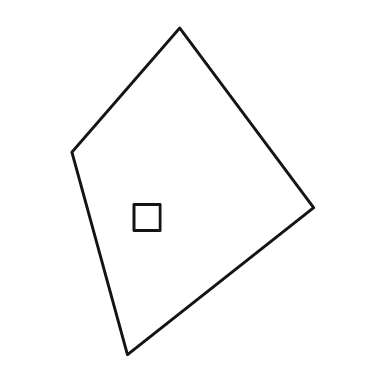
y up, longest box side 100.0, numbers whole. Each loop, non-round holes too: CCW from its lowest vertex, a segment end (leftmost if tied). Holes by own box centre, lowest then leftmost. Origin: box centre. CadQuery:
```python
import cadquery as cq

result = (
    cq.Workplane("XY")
    .moveTo(-20.0, -50.0)
    .lineTo(37.0, -5.0)
    .lineTo(-4.0, 50.0)
    .lineTo(-37.0, 12.0)
    .close()
    .moveTo(-18.0, -12.0)
    .lineTo(-10.0, -12.0)
    .lineTo(-10.0, -4.0)
    .lineTo(-18.0, -4.0)
    .close()
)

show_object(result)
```